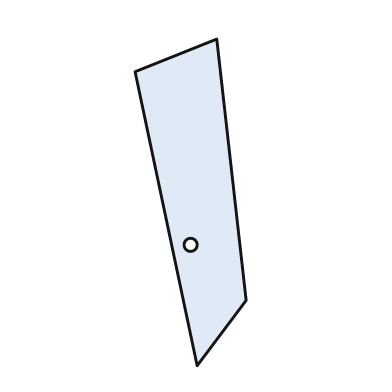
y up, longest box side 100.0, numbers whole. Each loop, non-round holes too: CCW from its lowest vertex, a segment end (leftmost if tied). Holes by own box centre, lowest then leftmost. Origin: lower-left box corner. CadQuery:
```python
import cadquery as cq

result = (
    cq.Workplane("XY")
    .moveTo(19.0, 0.0)
    .lineTo(34.0, 20.0)
    .lineTo(25.0, 100.0)
    .lineTo(0.0, 90.0)
    .close()
    .moveTo(17.0, 37.0)
    .circle(2.0)
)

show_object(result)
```